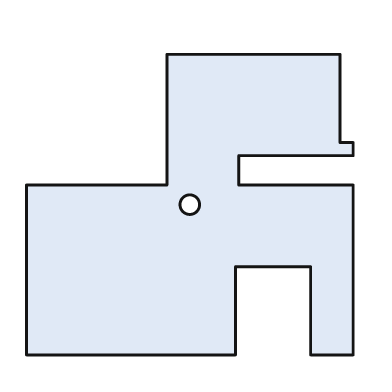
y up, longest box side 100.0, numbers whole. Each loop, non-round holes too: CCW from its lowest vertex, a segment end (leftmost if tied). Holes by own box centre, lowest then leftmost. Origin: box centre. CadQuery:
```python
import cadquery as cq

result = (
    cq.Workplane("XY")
    .moveTo(-50.0, -46.0)
    .lineTo(14.0, -46.0)
    .lineTo(14.0, -19.0)
    .lineTo(37.0, -19.0)
    .lineTo(37.0, -46.0)
    .lineTo(50.0, -46.0)
    .lineTo(50.0, 6.0)
    .lineTo(15.0, 6.0)
    .lineTo(15.0, 15.0)
    .lineTo(50.0, 15.0)
    .lineTo(50.0, 19.0)
    .lineTo(46.0, 19.0)
    .lineTo(46.0, 46.0)
    .lineTo(-7.0, 46.0)
    .lineTo(-7.0, 6.0)
    .lineTo(-50.0, 6.0)
    .close()
    .moveTo(0.0, 0.0)
    .circle(3.0)
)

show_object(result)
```